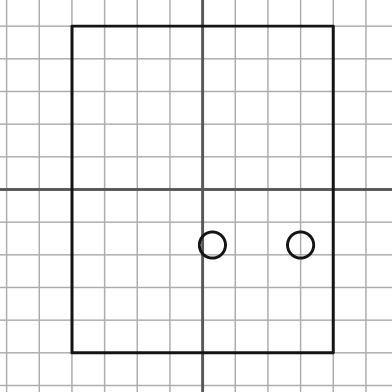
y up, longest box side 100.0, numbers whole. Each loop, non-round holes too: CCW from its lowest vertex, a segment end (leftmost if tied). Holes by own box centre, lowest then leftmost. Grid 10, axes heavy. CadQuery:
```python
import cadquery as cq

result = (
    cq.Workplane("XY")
    .moveTo(-40.0, -50.0)
    .lineTo(40.0, -50.0)
    .lineTo(40.0, 50.0)
    .lineTo(-40.0, 50.0)
    .close()
    .moveTo(3.0, -17.0)
    .circle(4.0)
    .moveTo(30.0, -17.0)
    .circle(4.0)
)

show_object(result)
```